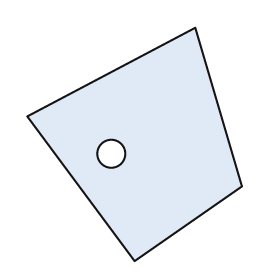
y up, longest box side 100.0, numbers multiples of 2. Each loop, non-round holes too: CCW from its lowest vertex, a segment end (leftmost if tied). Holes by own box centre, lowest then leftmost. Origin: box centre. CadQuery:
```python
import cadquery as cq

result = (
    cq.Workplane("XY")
    .moveTo(0.0, -50.0)
    .lineTo(46.0, -18.0)
    .lineTo(26.0, 50.0)
    .lineTo(-46.0, 12.0)
    .close()
    .moveTo(-10.0, -4.0)
    .circle(6.0)
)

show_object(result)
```